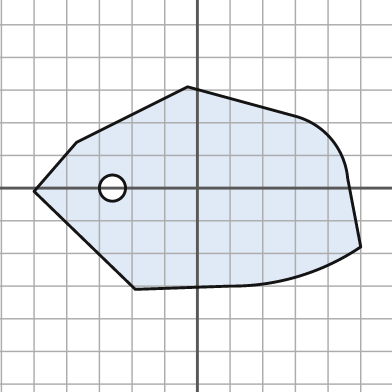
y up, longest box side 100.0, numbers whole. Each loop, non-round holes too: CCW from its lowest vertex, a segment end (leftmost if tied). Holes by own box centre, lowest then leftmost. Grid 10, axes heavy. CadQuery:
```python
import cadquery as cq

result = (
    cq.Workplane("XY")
    .moveTo(-19.0, -31.0)
    .lineTo(10.0, -30.0)
    .threePointArc((31.0, -27.0), (50.0, -18.0))
    .lineTo(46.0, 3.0)
    .threePointArc((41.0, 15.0), (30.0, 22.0))
    .lineTo(-3.0, 31.0)
    .lineTo(-37.0, 14.0)
    .lineTo(-50.0, -1.0)
    .close()
    .moveTo(-26.0, 0.0)
    .circle(4.0)
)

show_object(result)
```